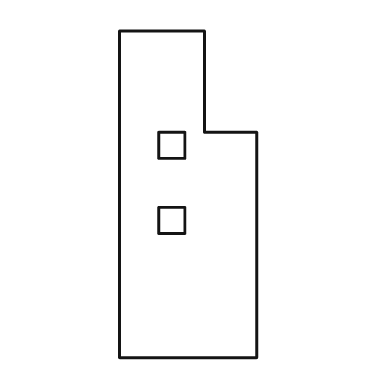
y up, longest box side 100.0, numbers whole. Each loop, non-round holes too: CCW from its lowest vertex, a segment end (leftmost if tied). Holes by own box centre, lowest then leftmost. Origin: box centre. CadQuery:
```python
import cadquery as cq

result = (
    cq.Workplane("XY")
    .moveTo(-21.0, -50.0)
    .lineTo(21.0, -50.0)
    .lineTo(21.0, 19.0)
    .lineTo(5.0, 19.0)
    .lineTo(5.0, 50.0)
    .lineTo(-21.0, 50.0)
    .close()
    .moveTo(-9.0, -12.0)
    .lineTo(-1.0, -12.0)
    .lineTo(-1.0, -4.0)
    .lineTo(-9.0, -4.0)
    .close()
    .moveTo(-9.0, 11.0)
    .lineTo(-1.0, 11.0)
    .lineTo(-1.0, 19.0)
    .lineTo(-9.0, 19.0)
    .close()
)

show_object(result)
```